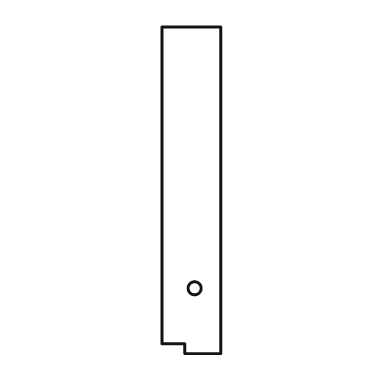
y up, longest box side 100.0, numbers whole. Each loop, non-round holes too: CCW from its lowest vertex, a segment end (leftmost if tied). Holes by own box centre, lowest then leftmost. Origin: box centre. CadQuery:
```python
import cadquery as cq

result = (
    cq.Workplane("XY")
    .moveTo(-2.0, -50.0)
    .lineTo(9.0, -50.0)
    .lineTo(9.0, 50.0)
    .lineTo(-9.0, 50.0)
    .lineTo(-9.0, -47.0)
    .lineTo(-2.0, -47.0)
    .close()
    .moveTo(1.0, -30.0)
    .circle(2.0)
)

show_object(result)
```